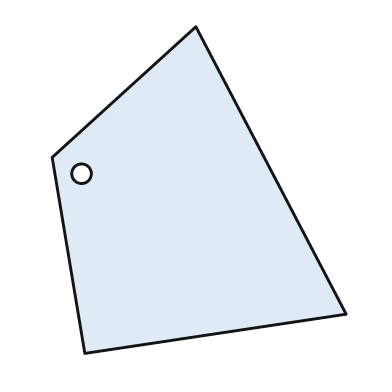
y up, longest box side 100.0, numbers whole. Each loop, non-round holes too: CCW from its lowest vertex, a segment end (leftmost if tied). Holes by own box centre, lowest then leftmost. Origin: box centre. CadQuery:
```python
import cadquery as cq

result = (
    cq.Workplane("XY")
    .moveTo(-35.0, -50.0)
    .lineTo(45.0, -38.0)
    .lineTo(-1.0, 50.0)
    .lineTo(-45.0, 10.0)
    .close()
    .moveTo(-36.0, 5.0)
    .circle(3.0)
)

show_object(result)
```